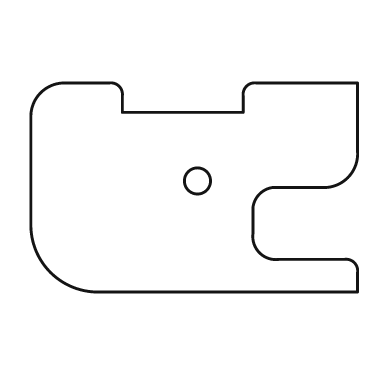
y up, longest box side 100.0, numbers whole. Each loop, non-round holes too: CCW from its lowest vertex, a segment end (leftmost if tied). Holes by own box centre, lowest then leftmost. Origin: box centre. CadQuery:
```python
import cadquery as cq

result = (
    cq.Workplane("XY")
    .moveTo(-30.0, -32.0)
    .lineTo(50.0, -32.0)
    .lineTo(50.0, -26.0)
    .threePointArc((49.0, -23.0), (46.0, -22.0))
    .lineTo(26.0, -22.0)
    .threePointArc((20.0, -20.0), (18.0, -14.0))
    .lineTo(18.0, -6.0)
    .threePointArc((20.0, -2.0), (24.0, 0.0))
    .lineTo(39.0, 0.0)
    .threePointArc((47.0, 3.0), (50.0, 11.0))
    .lineTo(50.0, 32.0)
    .lineTo(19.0, 32.0)
    .threePointArc((16.0, 31.0), (15.0, 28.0))
    .lineTo(15.0, 23.0)
    .lineTo(-22.0, 23.0)
    .lineTo(-22.0, 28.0)
    .threePointArc((-23.0, 31.0), (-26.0, 32.0))
    .lineTo(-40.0, 32.0)
    .threePointArc((-47.0, 29.0), (-50.0, 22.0))
    .lineTo(-50.0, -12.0)
    .threePointArc((-44.0, -26.0), (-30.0, -32.0))
    .close()
    .moveTo(1.0, 2.0)
    .circle(4.0)
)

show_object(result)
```